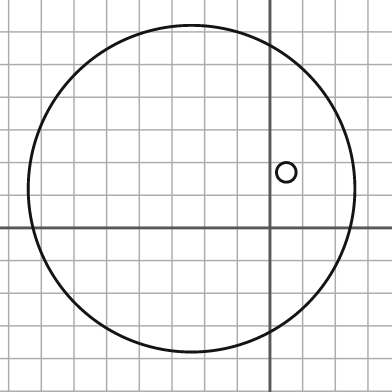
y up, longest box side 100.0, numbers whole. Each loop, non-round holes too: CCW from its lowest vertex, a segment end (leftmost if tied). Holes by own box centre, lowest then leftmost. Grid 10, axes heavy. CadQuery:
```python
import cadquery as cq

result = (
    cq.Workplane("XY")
    .moveTo(-24.0, 12.0)
    .circle(50.0)
    .moveTo(5.0, 17.0)
    .circle(3.0)
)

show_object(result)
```